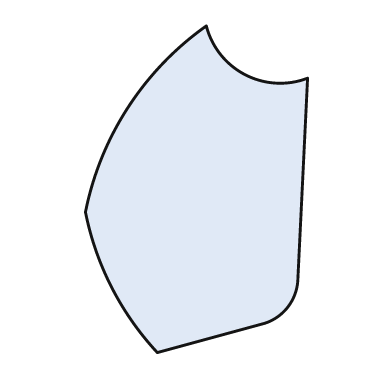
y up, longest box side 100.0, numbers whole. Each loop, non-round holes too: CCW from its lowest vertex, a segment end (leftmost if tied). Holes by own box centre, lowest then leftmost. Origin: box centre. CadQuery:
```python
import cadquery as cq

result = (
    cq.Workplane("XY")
    .moveTo(-12.0, -50.0)
    .lineTo(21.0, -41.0)
    .threePointArc((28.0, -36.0), (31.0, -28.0))
    .lineTo(34.0, 34.0)
    .threePointArc((15.0, 35.0), (3.0, 50.0))
    .threePointArc((-21.0, 25.0), (-34.0, -7.0))
    .threePointArc((-26.0, -30.0), (-12.0, -50.0))
    .close()
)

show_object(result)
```